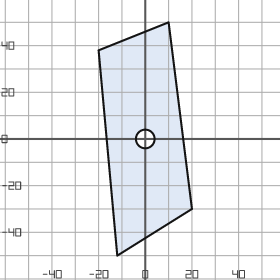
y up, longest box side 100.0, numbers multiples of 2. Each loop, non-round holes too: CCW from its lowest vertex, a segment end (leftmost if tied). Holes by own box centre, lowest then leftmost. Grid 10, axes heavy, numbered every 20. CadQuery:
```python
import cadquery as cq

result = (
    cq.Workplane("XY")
    .moveTo(-12.0, -50.0)
    .lineTo(20.0, -30.0)
    .lineTo(10.0, 50.0)
    .lineTo(-20.0, 38.0)
    .close()
    .moveTo(0.0, 0.0)
    .circle(4.0)
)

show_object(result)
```